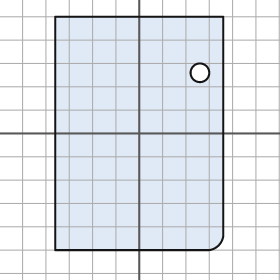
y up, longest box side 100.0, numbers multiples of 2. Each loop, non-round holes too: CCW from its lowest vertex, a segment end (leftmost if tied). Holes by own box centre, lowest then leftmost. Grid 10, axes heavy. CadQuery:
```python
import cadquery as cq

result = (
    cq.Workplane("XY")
    .moveTo(-36.0, -50.0)
    .lineTo(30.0, -50.0)
    .threePointArc((34.0, -48.0), (36.0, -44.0))
    .lineTo(36.0, 50.0)
    .lineTo(-36.0, 50.0)
    .close()
    .moveTo(26.0, 26.0)
    .circle(4.0)
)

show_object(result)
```